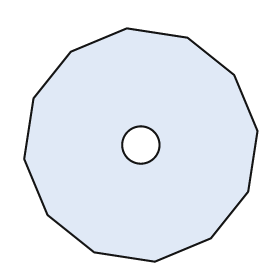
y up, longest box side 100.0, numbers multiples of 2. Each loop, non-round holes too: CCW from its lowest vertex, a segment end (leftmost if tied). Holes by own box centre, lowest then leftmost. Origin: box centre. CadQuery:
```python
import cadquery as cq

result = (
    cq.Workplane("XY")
    .moveTo(6.0, -50.0)
    .lineTo(30.0, -40.0)
    .lineTo(46.0, -20.0)
    .lineTo(50.0, 6.0)
    .lineTo(40.0, 30.0)
    .lineTo(20.0, 46.0)
    .lineTo(-6.0, 50.0)
    .lineTo(-30.0, 40.0)
    .lineTo(-46.0, 20.0)
    .lineTo(-50.0, -6.0)
    .lineTo(-40.0, -30.0)
    .lineTo(-20.0, -46.0)
    .close()
    .moveTo(0.0, 0.0)
    .circle(8.0)
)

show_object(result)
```